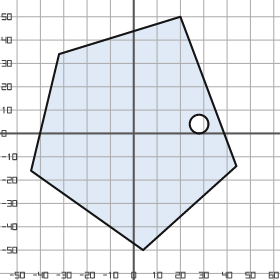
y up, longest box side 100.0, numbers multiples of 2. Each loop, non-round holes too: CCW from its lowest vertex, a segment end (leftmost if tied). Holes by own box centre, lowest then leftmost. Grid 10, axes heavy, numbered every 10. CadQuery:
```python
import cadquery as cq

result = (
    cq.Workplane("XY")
    .moveTo(4.0, -50.0)
    .lineTo(44.0, -14.0)
    .lineTo(20.0, 50.0)
    .lineTo(-32.0, 34.0)
    .lineTo(-44.0, -16.0)
    .close()
    .moveTo(28.0, 4.0)
    .circle(4.0)
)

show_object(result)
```